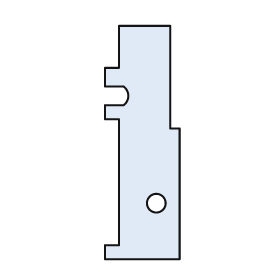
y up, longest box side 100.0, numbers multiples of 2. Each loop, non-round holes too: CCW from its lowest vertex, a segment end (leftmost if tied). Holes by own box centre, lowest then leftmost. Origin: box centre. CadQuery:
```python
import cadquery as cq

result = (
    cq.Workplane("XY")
    .moveTo(-16.0, -50.0)
    .lineTo(16.0, -50.0)
    .lineTo(16.0, 6.0)
    .lineTo(12.0, 6.0)
    .lineTo(12.0, 50.0)
    .lineTo(-10.0, 50.0)
    .lineTo(-10.0, 32.0)
    .lineTo(-16.0, 32.0)
    .lineTo(-16.0, 24.0)
    .lineTo(-8.0, 24.0)
    .threePointArc((-6.0, 20.0), (-8.0, 16.0))
    .lineTo(-16.0, 16.0)
    .lineTo(-16.0, 10.0)
    .lineTo(-10.0, 10.0)
    .lineTo(-10.0, -44.0)
    .lineTo(-16.0, -44.0)
    .close()
    .moveTo(6.0, -26.0)
    .circle(4.0)
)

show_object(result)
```